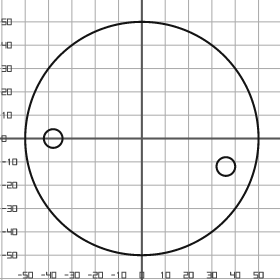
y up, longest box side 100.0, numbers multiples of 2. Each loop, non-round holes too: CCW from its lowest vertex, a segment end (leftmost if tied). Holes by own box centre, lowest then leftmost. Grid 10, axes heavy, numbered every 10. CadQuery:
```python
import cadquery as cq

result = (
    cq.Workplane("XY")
    .moveTo(0.0, 0.0)
    .circle(50.0)
    .moveTo(36.0, -12.0)
    .circle(4.0)
    .moveTo(-38.0, 0.0)
    .circle(4.0)
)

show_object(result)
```